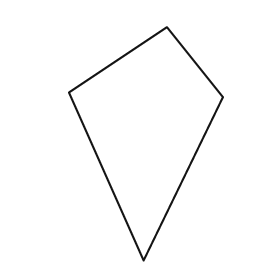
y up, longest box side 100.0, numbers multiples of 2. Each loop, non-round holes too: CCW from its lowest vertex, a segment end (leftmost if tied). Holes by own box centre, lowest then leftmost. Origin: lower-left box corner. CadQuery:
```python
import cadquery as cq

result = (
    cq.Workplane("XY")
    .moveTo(32.0, 0.0)
    .lineTo(66.0, 70.0)
    .lineTo(42.0, 100.0)
    .lineTo(0.0, 72.0)
    .close()
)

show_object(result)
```